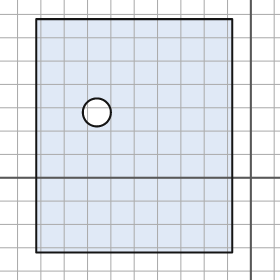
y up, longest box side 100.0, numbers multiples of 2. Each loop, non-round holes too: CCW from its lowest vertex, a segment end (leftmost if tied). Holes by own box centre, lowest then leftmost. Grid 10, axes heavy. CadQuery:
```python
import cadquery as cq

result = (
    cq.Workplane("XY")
    .moveTo(-92.0, -32.0)
    .lineTo(-8.0, -32.0)
    .lineTo(-8.0, 68.0)
    .lineTo(-92.0, 68.0)
    .close()
    .moveTo(-66.0, 28.0)
    .circle(6.0)
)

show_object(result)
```